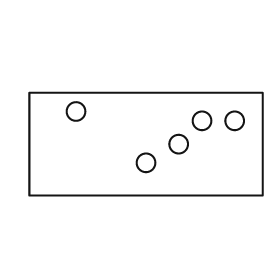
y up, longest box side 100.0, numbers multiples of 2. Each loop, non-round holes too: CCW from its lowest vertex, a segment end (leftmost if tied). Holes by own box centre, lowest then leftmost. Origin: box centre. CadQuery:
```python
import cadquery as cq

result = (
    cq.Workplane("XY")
    .moveTo(-50.0, -22.0)
    .lineTo(50.0, -22.0)
    .lineTo(50.0, 22.0)
    .lineTo(-50.0, 22.0)
    .close()
    .moveTo(0.0, -8.0)
    .circle(4.0)
    .moveTo(14.0, 0.0)
    .circle(4.0)
    .moveTo(24.0, 10.0)
    .circle(4.0)
    .moveTo(38.0, 10.0)
    .circle(4.0)
    .moveTo(-30.0, 14.0)
    .circle(4.0)
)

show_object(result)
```